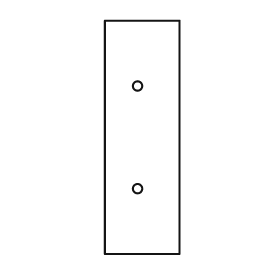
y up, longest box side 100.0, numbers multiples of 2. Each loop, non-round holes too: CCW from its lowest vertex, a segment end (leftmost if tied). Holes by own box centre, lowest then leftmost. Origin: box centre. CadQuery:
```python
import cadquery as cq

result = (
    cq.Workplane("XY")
    .moveTo(-16.0, -50.0)
    .lineTo(16.0, -50.0)
    .lineTo(16.0, 50.0)
    .lineTo(-16.0, 50.0)
    .close()
    .moveTo(-2.0, -22.0)
    .circle(2.0)
    .moveTo(-2.0, 22.0)
    .circle(2.0)
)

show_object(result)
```